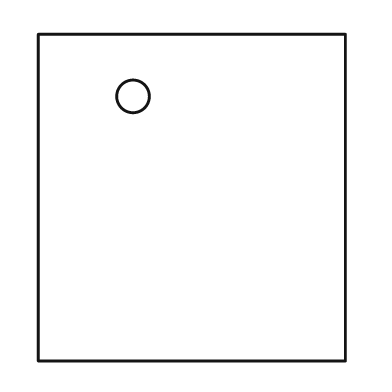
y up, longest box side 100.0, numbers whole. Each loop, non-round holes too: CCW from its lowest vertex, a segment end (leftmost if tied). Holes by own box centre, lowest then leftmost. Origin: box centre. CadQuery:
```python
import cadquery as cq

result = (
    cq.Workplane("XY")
    .moveTo(-47.0, -50.0)
    .lineTo(47.0, -50.0)
    .lineTo(47.0, 50.0)
    .lineTo(-47.0, 50.0)
    .close()
    .moveTo(-18.0, 31.0)
    .circle(5.0)
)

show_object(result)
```